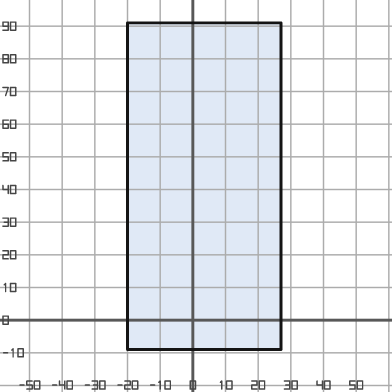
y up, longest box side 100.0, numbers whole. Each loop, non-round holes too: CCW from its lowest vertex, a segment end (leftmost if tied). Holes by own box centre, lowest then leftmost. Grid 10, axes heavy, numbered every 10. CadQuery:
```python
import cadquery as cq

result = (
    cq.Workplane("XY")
    .moveTo(-20.0, -9.0)
    .lineTo(27.0, -9.0)
    .lineTo(27.0, 91.0)
    .lineTo(-20.0, 91.0)
    .close()
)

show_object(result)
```